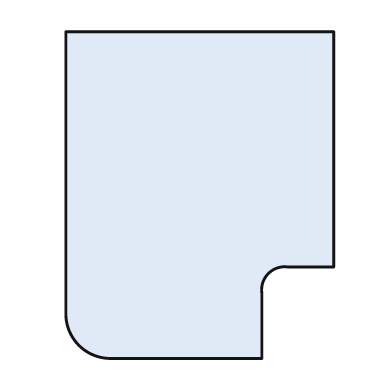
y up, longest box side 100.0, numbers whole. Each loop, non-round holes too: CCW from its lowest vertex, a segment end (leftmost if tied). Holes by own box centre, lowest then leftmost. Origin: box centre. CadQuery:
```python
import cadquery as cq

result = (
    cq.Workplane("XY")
    .moveTo(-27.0, -50.0)
    .lineTo(19.0, -50.0)
    .lineTo(19.0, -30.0)
    .threePointArc((21.0, -24.0), (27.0, -22.0))
    .lineTo(41.0, -22.0)
    .lineTo(41.0, 50.0)
    .lineTo(-41.0, 50.0)
    .lineTo(-41.0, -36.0)
    .threePointArc((-37.0, -46.0), (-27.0, -50.0))
    .close()
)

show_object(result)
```